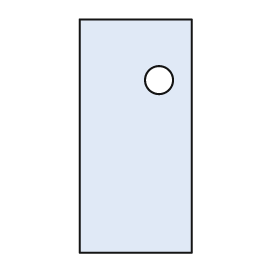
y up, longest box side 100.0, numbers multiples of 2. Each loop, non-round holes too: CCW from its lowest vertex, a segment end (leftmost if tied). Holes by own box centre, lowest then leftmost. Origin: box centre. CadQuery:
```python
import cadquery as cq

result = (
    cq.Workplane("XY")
    .moveTo(-24.0, -50.0)
    .lineTo(24.0, -50.0)
    .lineTo(24.0, 50.0)
    .lineTo(-24.0, 50.0)
    .close()
    .moveTo(10.0, 24.0)
    .circle(6.0)
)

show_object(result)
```